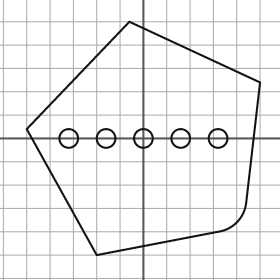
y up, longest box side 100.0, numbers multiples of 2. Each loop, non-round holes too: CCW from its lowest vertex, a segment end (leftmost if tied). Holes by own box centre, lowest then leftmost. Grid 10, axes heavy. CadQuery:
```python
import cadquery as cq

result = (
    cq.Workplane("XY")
    .moveTo(-20.0, -50.0)
    .lineTo(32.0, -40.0)
    .threePointArc((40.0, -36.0), (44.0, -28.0))
    .lineTo(50.0, 24.0)
    .lineTo(-6.0, 50.0)
    .lineTo(-50.0, 4.0)
    .close()
    .moveTo(-32.0, 0.0)
    .circle(4.0)
    .moveTo(-16.0, 0.0)
    .circle(4.0)
    .moveTo(0.0, 0.0)
    .circle(4.0)
    .moveTo(16.0, 0.0)
    .circle(4.0)
    .moveTo(32.0, 0.0)
    .circle(4.0)
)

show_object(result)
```